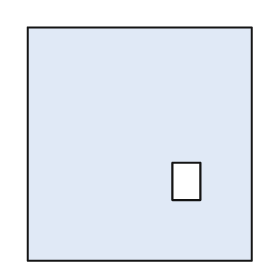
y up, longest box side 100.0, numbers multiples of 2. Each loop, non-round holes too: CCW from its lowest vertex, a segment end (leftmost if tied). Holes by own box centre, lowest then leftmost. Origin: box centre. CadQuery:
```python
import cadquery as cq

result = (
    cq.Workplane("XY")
    .moveTo(-48.0, -50.0)
    .lineTo(48.0, -50.0)
    .lineTo(48.0, 50.0)
    .lineTo(-48.0, 50.0)
    .close()
    .moveTo(14.0, -24.0)
    .lineTo(26.0, -24.0)
    .lineTo(26.0, -8.0)
    .lineTo(14.0, -8.0)
    .close()
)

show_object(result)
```